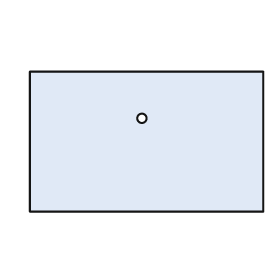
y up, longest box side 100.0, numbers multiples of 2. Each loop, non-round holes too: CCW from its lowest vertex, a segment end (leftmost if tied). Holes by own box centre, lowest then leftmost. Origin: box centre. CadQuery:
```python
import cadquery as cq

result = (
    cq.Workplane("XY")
    .moveTo(-50.0, -30.0)
    .lineTo(50.0, -30.0)
    .lineTo(50.0, 30.0)
    .lineTo(-50.0, 30.0)
    .close()
    .moveTo(-2.0, 10.0)
    .circle(2.0)
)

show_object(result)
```